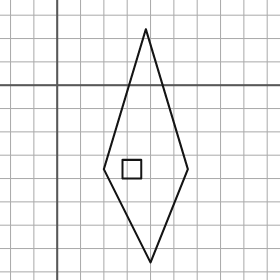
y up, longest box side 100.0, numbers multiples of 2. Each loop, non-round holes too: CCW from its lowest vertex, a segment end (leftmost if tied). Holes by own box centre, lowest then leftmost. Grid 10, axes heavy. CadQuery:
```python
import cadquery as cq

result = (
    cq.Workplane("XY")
    .moveTo(40.0, -76.0)
    .lineTo(56.0, -36.0)
    .lineTo(38.0, 24.0)
    .lineTo(20.0, -36.0)
    .close()
    .moveTo(28.0, -40.0)
    .lineTo(36.0, -40.0)
    .lineTo(36.0, -32.0)
    .lineTo(28.0, -32.0)
    .close()
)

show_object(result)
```